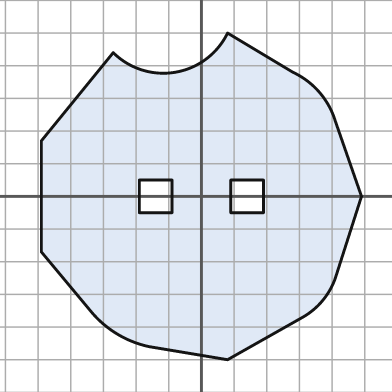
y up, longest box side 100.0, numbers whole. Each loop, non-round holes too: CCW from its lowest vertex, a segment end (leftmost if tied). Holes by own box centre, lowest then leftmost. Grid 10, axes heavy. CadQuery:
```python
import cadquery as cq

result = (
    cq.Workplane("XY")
    .moveTo(8.0, -50.0)
    .lineTo(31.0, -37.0)
    .threePointArc((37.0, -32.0), (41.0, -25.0))
    .lineTo(49.0, 0.0)
    .lineTo(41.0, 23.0)
    .threePointArc((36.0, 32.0), (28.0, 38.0))
    .lineTo(8.0, 50.0)
    .threePointArc((-8.0, 38.0), (-27.0, 44.0))
    .lineTo(-49.0, 17.0)
    .lineTo(-49.0, -17.0)
    .lineTo(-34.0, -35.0)
    .threePointArc((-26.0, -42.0), (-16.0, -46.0))
    .close()
    .moveTo(-19.0, -5.0)
    .lineTo(-9.0, -5.0)
    .lineTo(-9.0, 5.0)
    .lineTo(-19.0, 5.0)
    .close()
    .moveTo(9.0, -5.0)
    .lineTo(19.0, -5.0)
    .lineTo(19.0, 5.0)
    .lineTo(9.0, 5.0)
    .close()
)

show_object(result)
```